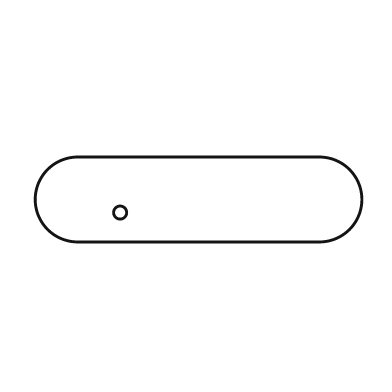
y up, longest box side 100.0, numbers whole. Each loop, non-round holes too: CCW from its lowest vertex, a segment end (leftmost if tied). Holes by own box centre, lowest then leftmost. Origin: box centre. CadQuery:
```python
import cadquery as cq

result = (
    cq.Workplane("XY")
    .moveTo(-37.0, -13.0)
    .lineTo(37.0, -13.0)
    .threePointArc((50.0, 0.0), (37.0, 13.0))
    .lineTo(-37.0, 13.0)
    .threePointArc((-50.0, 0.0), (-37.0, -13.0))
    .close()
    .moveTo(-24.0, -4.0)
    .circle(2.0)
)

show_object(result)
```